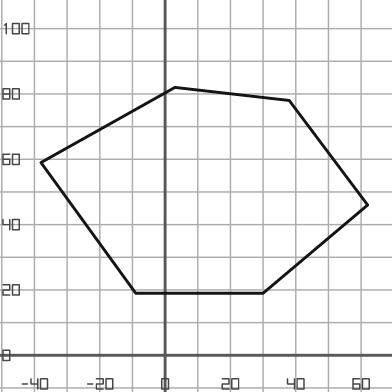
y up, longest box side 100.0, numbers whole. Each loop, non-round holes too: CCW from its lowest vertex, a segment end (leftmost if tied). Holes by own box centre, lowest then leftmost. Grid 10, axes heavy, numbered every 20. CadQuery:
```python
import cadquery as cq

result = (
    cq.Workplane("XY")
    .moveTo(-9.0, 19.0)
    .lineTo(30.0, 19.0)
    .lineTo(62.0, 46.0)
    .lineTo(38.0, 78.0)
    .lineTo(3.0, 82.0)
    .lineTo(-38.0, 59.0)
    .close()
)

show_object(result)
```